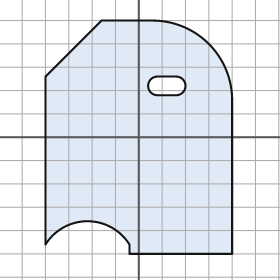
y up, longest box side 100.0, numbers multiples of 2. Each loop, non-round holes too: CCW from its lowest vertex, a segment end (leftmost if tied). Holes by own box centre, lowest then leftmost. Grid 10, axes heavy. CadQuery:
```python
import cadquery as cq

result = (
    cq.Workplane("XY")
    .moveTo(-4.0, -50.0)
    .lineTo(40.0, -50.0)
    .lineTo(40.0, 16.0)
    .threePointArc((30.0, 40.0), (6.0, 50.0))
    .lineTo(-16.0, 50.0)
    .lineTo(-40.0, 26.0)
    .lineTo(-40.0, -46.0)
    .threePointArc((-22.0, -36.0), (-4.0, -46.0))
    .close()
    .moveTo(8.0, 18.0)
    .lineTo(16.0, 18.0)
    .threePointArc((20.0, 22.0), (16.0, 26.0))
    .lineTo(8.0, 26.0)
    .threePointArc((4.0, 22.0), (8.0, 18.0))
    .close()
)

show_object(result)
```